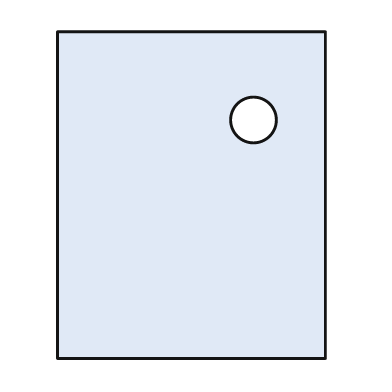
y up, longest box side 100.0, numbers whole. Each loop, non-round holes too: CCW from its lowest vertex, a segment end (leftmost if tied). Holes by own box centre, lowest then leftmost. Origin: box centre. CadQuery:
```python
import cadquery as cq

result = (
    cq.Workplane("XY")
    .moveTo(-41.0, -50.0)
    .lineTo(41.0, -50.0)
    .lineTo(41.0, 50.0)
    .lineTo(-41.0, 50.0)
    .close()
    .moveTo(19.0, 23.0)
    .circle(7.0)
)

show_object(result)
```